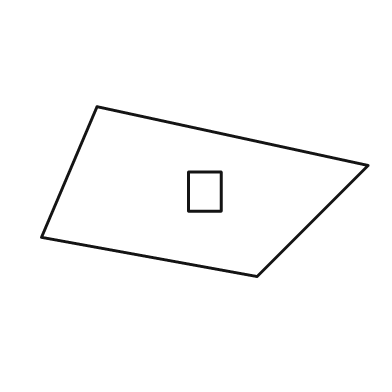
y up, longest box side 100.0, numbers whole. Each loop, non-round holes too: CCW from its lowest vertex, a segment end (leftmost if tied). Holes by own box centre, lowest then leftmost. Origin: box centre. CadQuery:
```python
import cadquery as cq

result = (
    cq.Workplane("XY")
    .moveTo(16.0, -26.0)
    .lineTo(50.0, 8.0)
    .lineTo(-33.0, 26.0)
    .lineTo(-50.0, -14.0)
    .close()
    .moveTo(-5.0, -6.0)
    .lineTo(5.0, -6.0)
    .lineTo(5.0, 6.0)
    .lineTo(-5.0, 6.0)
    .close()
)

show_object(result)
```